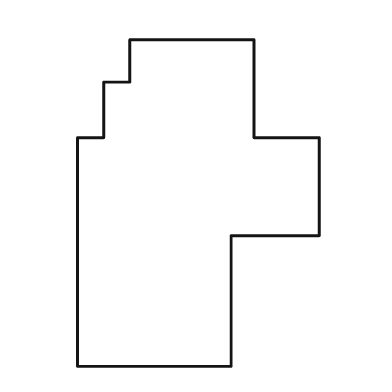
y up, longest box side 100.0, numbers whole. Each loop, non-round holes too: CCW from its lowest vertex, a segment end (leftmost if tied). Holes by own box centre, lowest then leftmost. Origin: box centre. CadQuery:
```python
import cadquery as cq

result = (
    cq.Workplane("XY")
    .moveTo(-37.0, -50.0)
    .lineTo(10.0, -50.0)
    .lineTo(10.0, -10.0)
    .lineTo(37.0, -10.0)
    .lineTo(37.0, 20.0)
    .lineTo(17.0, 20.0)
    .lineTo(17.0, 50.0)
    .lineTo(-21.0, 50.0)
    .lineTo(-21.0, 37.0)
    .lineTo(-29.0, 37.0)
    .lineTo(-29.0, 20.0)
    .lineTo(-37.0, 20.0)
    .close()
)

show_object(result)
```